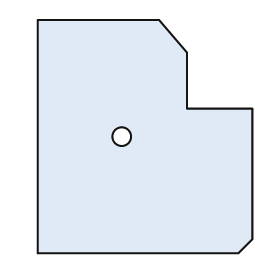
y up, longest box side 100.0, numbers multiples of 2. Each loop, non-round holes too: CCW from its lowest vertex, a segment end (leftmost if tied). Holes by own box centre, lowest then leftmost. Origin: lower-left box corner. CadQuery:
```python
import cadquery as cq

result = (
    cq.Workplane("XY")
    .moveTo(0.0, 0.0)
    .lineTo(86.0, 0.0)
    .lineTo(92.0, 6.0)
    .lineTo(92.0, 62.0)
    .lineTo(64.0, 62.0)
    .lineTo(64.0, 86.0)
    .lineTo(52.0, 100.0)
    .lineTo(0.0, 100.0)
    .close()
    .moveTo(36.0, 50.0)
    .circle(4.0)
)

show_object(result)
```